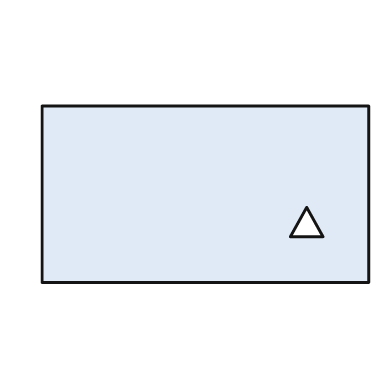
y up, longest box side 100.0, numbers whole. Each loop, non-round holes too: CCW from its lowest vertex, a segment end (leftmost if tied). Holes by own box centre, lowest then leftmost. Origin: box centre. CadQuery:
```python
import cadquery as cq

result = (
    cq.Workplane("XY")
    .moveTo(-50.0, -27.0)
    .lineTo(50.0, -27.0)
    .lineTo(50.0, 27.0)
    .lineTo(-50.0, 27.0)
    .close()
    .moveTo(26.0, -13.0)
    .lineTo(36.0, -13.0)
    .lineTo(31.0, -4.0)
    .close()
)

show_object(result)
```